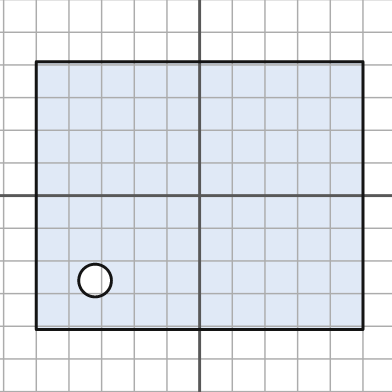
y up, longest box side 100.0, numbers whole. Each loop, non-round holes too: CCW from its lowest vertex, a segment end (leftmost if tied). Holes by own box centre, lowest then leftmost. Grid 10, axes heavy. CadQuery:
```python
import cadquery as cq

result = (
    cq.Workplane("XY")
    .moveTo(-50.0, -41.0)
    .lineTo(50.0, -41.0)
    .lineTo(50.0, 41.0)
    .lineTo(-50.0, 41.0)
    .close()
    .moveTo(-32.0, -26.0)
    .circle(5.0)
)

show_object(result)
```